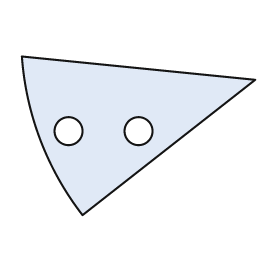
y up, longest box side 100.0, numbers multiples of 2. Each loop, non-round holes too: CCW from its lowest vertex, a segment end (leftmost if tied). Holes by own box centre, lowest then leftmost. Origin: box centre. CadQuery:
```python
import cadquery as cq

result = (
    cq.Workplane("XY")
    .moveTo(-24.0, -34.0)
    .lineTo(50.0, 24.0)
    .lineTo(-50.0, 34.0)
    .threePointArc((-42.0, -2.0), (-24.0, -34.0))
    .close()
    .moveTo(-30.0, 2.0)
    .circle(6.0)
    .moveTo(0.0, 2.0)
    .circle(6.0)
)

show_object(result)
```